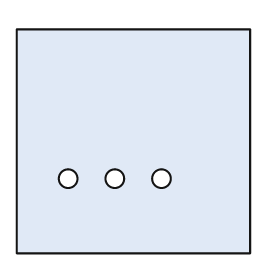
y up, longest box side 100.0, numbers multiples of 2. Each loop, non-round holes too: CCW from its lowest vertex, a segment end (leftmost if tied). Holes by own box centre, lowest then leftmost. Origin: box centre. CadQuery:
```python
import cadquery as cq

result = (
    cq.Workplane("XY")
    .moveTo(-50.0, -48.0)
    .lineTo(50.0, -48.0)
    .lineTo(50.0, 48.0)
    .lineTo(-50.0, 48.0)
    .close()
    .moveTo(-28.0, -16.0)
    .circle(4.0)
    .moveTo(-8.0, -16.0)
    .circle(4.0)
    .moveTo(12.0, -16.0)
    .circle(4.0)
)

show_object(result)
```